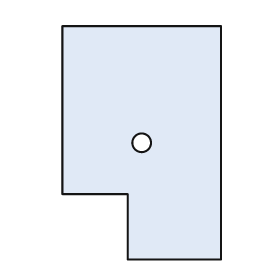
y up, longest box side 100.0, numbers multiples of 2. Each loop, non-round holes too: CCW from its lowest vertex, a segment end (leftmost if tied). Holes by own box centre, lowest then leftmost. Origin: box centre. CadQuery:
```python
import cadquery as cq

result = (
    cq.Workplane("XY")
    .moveTo(-6.0, -50.0)
    .lineTo(34.0, -50.0)
    .lineTo(34.0, 50.0)
    .lineTo(-34.0, 50.0)
    .lineTo(-34.0, -22.0)
    .lineTo(-6.0, -22.0)
    .close()
    .moveTo(0.0, 0.0)
    .circle(4.0)
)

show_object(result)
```